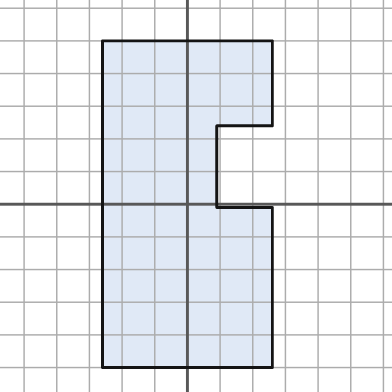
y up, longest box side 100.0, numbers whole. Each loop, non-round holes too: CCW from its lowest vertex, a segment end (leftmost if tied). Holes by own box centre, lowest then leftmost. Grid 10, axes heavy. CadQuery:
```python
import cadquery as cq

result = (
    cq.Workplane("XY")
    .moveTo(-26.0, -50.0)
    .lineTo(26.0, -50.0)
    .lineTo(26.0, -1.0)
    .lineTo(9.0, -1.0)
    .lineTo(9.0, 24.0)
    .lineTo(26.0, 24.0)
    .lineTo(26.0, 50.0)
    .lineTo(-26.0, 50.0)
    .close()
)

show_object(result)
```